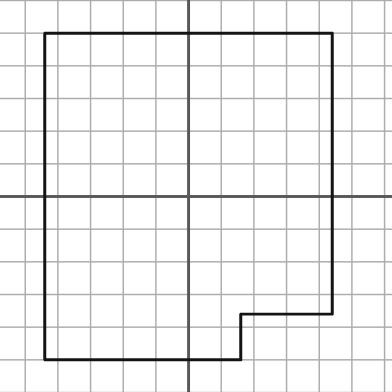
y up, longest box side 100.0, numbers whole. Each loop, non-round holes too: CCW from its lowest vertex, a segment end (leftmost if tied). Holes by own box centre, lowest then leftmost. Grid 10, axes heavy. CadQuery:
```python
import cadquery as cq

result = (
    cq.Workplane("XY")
    .moveTo(-44.0, -50.0)
    .lineTo(16.0, -50.0)
    .lineTo(16.0, -36.0)
    .lineTo(44.0, -36.0)
    .lineTo(44.0, 50.0)
    .lineTo(-44.0, 50.0)
    .close()
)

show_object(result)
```